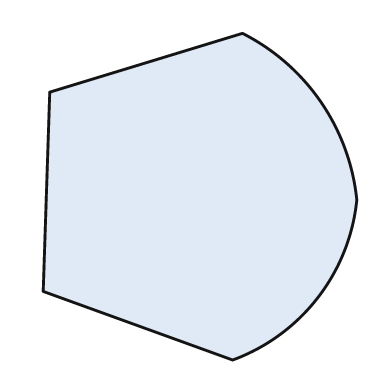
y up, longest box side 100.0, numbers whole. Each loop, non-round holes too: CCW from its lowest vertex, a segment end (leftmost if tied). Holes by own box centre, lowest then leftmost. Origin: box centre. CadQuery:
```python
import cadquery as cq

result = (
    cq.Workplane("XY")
    .moveTo(10.0, -50.0)
    .threePointArc((36.0, -31.0), (48.0, -1.0))
    .threePointArc((37.0, 29.0), (13.0, 50.0))
    .lineTo(-46.0, 32.0)
    .lineTo(-48.0, -29.0)
    .close()
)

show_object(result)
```